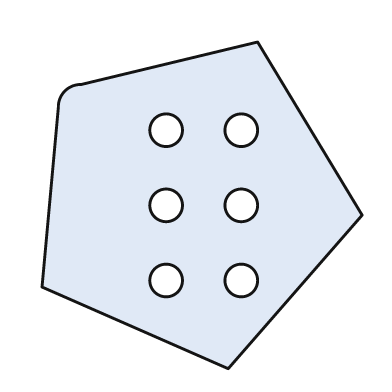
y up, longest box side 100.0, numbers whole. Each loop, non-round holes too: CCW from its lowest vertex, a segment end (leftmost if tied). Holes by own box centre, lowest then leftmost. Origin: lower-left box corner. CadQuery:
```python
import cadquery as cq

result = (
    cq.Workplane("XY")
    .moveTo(57.0, 0.0)
    .lineTo(98.0, 47.0)
    .lineTo(66.0, 100.0)
    .lineTo(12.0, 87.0)
    .threePointArc((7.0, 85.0), (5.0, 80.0))
    .lineTo(0.0, 25.0)
    .close()
    .moveTo(38.0, 27.0)
    .circle(5.0)
    .moveTo(61.0, 27.0)
    .circle(5.0)
    .moveTo(38.0, 50.0)
    .circle(5.0)
    .moveTo(61.0, 50.0)
    .circle(5.0)
    .moveTo(38.0, 73.0)
    .circle(5.0)
    .moveTo(61.0, 73.0)
    .circle(5.0)
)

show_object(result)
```